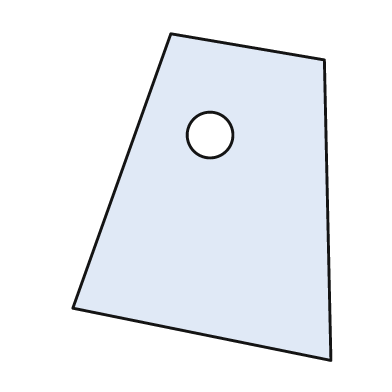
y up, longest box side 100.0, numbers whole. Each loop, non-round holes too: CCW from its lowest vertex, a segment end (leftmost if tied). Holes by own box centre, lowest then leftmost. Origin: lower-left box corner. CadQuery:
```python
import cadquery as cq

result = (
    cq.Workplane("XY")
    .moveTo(79.0, 0.0)
    .lineTo(77.0, 92.0)
    .lineTo(30.0, 100.0)
    .lineTo(0.0, 16.0)
    .close()
    .moveTo(42.0, 69.0)
    .circle(7.0)
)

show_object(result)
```